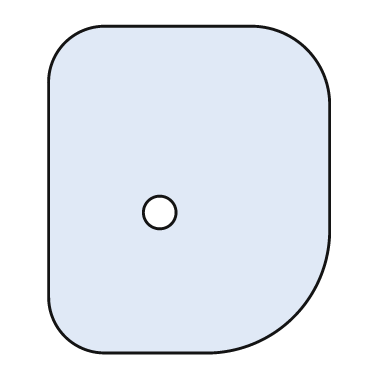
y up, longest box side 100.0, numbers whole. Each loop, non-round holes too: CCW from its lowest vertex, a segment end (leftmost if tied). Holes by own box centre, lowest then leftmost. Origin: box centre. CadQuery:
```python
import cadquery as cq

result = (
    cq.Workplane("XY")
    .moveTo(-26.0, -50.0)
    .lineTo(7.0, -50.0)
    .threePointArc((32.0, -39.0), (43.0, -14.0))
    .lineTo(43.0, 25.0)
    .threePointArc((36.0, 43.0), (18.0, 50.0))
    .lineTo(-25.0, 50.0)
    .threePointArc((-38.0, 45.0), (-43.0, 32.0))
    .lineTo(-43.0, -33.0)
    .threePointArc((-38.0, -45.0), (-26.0, -50.0))
    .close()
    .moveTo(-9.0, -7.0)
    .circle(5.0)
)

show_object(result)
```